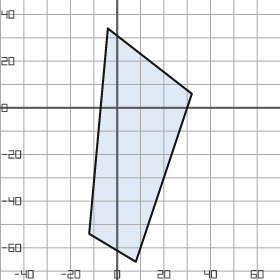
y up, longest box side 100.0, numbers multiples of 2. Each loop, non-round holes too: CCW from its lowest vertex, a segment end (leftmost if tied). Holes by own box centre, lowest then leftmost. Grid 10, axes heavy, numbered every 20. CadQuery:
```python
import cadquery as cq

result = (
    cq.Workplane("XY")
    .moveTo(8.0, -66.0)
    .lineTo(32.0, 6.0)
    .lineTo(-4.0, 34.0)
    .lineTo(-12.0, -54.0)
    .close()
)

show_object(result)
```